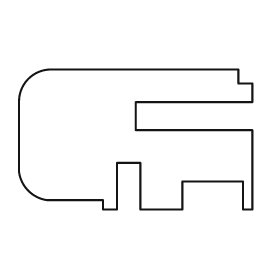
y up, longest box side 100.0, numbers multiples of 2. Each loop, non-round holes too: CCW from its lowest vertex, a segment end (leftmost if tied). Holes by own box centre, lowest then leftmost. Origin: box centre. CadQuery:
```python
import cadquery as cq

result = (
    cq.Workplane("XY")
    .moveTo(-14.0, -30.0)
    .lineTo(-8.0, -30.0)
    .lineTo(-8.0, -10.0)
    .lineTo(2.0, -10.0)
    .lineTo(2.0, -30.0)
    .lineTo(20.0, -30.0)
    .lineTo(20.0, -18.0)
    .lineTo(46.0, -18.0)
    .lineTo(46.0, -30.0)
    .lineTo(50.0, -30.0)
    .lineTo(50.0, 4.0)
    .lineTo(0.0, 4.0)
    .lineTo(0.0, 16.0)
    .lineTo(50.0, 16.0)
    .lineTo(50.0, 24.0)
    .lineTo(44.0, 24.0)
    .lineTo(44.0, 30.0)
    .lineTo(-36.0, 30.0)
    .threePointArc((-46.0, 26.0), (-50.0, 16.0))
    .lineTo(-50.0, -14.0)
    .threePointArc((-46.0, -22.0), (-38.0, -26.0))
    .lineTo(-14.0, -26.0)
    .close()
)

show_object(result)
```